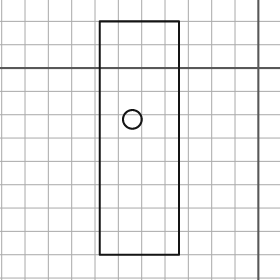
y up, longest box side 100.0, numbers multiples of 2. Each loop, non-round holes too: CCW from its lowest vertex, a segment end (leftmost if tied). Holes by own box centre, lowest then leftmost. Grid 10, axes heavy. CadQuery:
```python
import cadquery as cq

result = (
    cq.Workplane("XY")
    .moveTo(-68.0, -80.0)
    .lineTo(-34.0, -80.0)
    .lineTo(-34.0, 20.0)
    .lineTo(-68.0, 20.0)
    .close()
    .moveTo(-54.0, -22.0)
    .circle(4.0)
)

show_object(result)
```